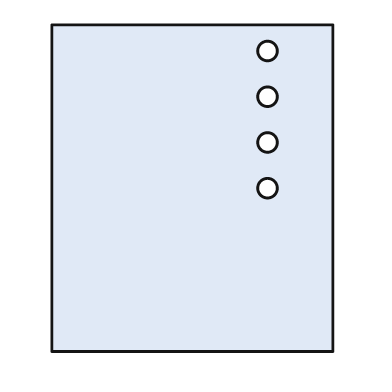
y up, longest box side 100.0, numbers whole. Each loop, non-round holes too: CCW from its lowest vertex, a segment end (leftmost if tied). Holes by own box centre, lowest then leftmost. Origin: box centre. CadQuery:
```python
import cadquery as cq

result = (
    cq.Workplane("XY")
    .moveTo(-43.0, -50.0)
    .lineTo(43.0, -50.0)
    .lineTo(43.0, 50.0)
    .lineTo(-43.0, 50.0)
    .close()
    .moveTo(23.0, 0.0)
    .circle(3.0)
    .moveTo(23.0, 14.0)
    .circle(3.0)
    .moveTo(23.0, 28.0)
    .circle(3.0)
    .moveTo(23.0, 42.0)
    .circle(3.0)
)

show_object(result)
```